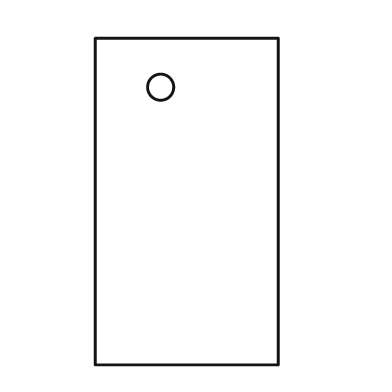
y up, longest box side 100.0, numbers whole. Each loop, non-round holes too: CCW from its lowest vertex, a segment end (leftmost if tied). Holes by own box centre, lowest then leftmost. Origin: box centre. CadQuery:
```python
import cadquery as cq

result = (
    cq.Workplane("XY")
    .moveTo(-28.0, -50.0)
    .lineTo(28.0, -50.0)
    .lineTo(28.0, 50.0)
    .lineTo(-28.0, 50.0)
    .close()
    .moveTo(-8.0, 35.0)
    .circle(4.0)
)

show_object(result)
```